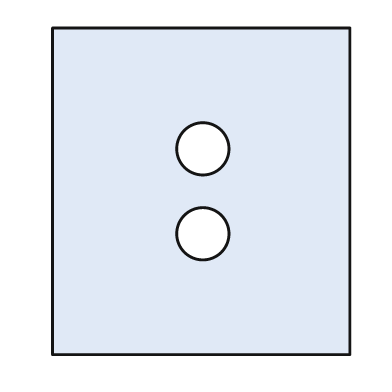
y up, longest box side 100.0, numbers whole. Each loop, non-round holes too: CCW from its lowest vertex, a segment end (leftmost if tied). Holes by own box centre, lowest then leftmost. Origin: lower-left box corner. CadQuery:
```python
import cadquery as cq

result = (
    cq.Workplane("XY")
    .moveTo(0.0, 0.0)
    .lineTo(91.0, 0.0)
    .lineTo(91.0, 100.0)
    .lineTo(0.0, 100.0)
    .close()
    .moveTo(46.0, 37.0)
    .circle(8.0)
    .moveTo(46.0, 63.0)
    .circle(8.0)
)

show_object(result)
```